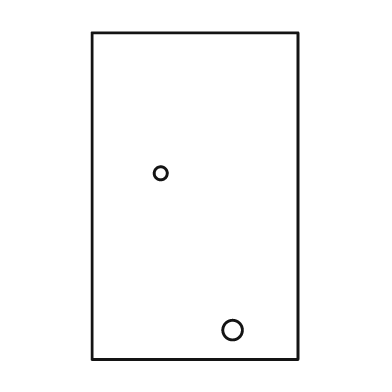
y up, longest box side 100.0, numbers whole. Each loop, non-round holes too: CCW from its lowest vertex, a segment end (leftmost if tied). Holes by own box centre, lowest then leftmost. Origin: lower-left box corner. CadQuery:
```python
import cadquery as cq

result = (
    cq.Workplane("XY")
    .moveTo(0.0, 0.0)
    .lineTo(63.0, 0.0)
    .lineTo(63.0, 100.0)
    .lineTo(0.0, 100.0)
    .close()
    .moveTo(43.0, 9.0)
    .circle(3.0)
    .moveTo(21.0, 57.0)
    .circle(2.0)
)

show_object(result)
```